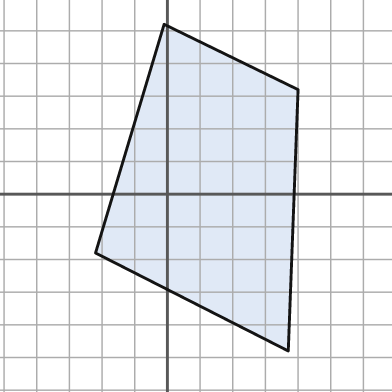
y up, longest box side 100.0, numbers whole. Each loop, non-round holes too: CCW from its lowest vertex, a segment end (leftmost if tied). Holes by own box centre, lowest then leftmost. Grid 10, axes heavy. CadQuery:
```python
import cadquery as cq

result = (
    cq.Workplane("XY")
    .moveTo(37.0, -48.0)
    .lineTo(40.0, 32.0)
    .lineTo(-1.0, 52.0)
    .lineTo(-22.0, -18.0)
    .close()
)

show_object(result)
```